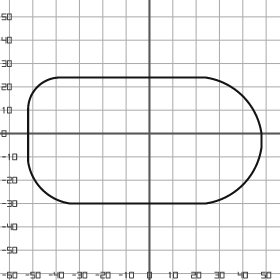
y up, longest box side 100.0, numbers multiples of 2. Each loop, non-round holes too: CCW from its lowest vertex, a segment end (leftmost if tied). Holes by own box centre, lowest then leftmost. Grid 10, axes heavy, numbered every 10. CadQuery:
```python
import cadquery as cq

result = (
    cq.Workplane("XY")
    .moveTo(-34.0, -30.0)
    .lineTo(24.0, -30.0)
    .threePointArc((40.0, -22.0), (48.0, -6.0))
    .lineTo(48.0, 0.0)
    .threePointArc((40.0, 16.0), (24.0, 24.0))
    .lineTo(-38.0, 24.0)
    .threePointArc((-48.0, 20.0), (-52.0, 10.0))
    .lineTo(-52.0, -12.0)
    .threePointArc((-46.0, -24.0), (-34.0, -30.0))
    .close()
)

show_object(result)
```